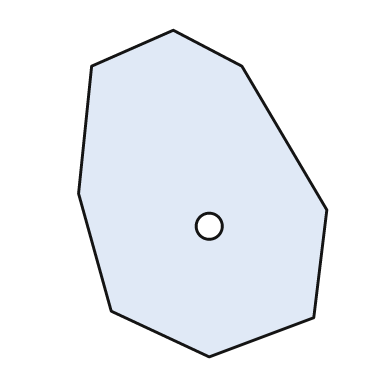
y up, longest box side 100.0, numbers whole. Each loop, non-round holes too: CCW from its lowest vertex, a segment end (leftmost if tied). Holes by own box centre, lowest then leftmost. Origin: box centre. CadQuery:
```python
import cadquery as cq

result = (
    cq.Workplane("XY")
    .moveTo(2.0, -50.0)
    .lineTo(34.0, -38.0)
    .lineTo(38.0, -5.0)
    .lineTo(12.0, 39.0)
    .lineTo(-9.0, 50.0)
    .lineTo(-34.0, 39.0)
    .lineTo(-38.0, 0.0)
    .lineTo(-28.0, -36.0)
    .close()
    .moveTo(2.0, -10.0)
    .circle(4.0)
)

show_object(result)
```